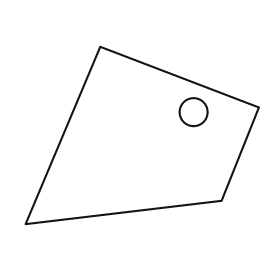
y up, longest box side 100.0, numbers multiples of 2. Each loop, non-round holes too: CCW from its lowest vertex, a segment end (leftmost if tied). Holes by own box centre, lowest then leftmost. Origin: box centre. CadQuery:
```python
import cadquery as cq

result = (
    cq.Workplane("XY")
    .moveTo(-50.0, -38.0)
    .lineTo(34.0, -28.0)
    .lineTo(50.0, 12.0)
    .lineTo(-18.0, 38.0)
    .close()
    .moveTo(22.0, 10.0)
    .circle(6.0)
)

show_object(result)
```